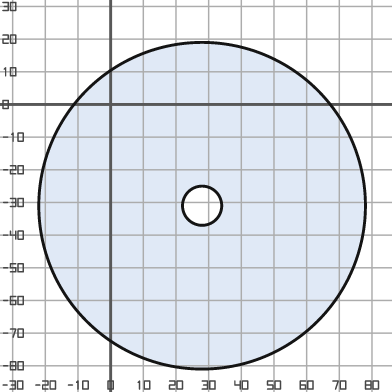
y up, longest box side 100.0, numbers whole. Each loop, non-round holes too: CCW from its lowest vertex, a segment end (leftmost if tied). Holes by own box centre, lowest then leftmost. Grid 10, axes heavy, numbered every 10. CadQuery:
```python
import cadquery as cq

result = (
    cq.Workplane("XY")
    .moveTo(28.0, -31.0)
    .circle(50.0)
    .moveTo(28.0, -31.0)
    .circle(6.0)
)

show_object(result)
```